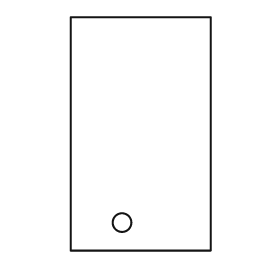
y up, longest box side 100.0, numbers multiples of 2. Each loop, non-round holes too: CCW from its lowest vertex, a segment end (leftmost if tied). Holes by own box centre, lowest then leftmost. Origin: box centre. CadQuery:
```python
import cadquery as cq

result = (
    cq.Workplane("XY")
    .moveTo(-30.0, -50.0)
    .lineTo(30.0, -50.0)
    .lineTo(30.0, 50.0)
    .lineTo(-30.0, 50.0)
    .close()
    .moveTo(-8.0, -38.0)
    .circle(4.0)
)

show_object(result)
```